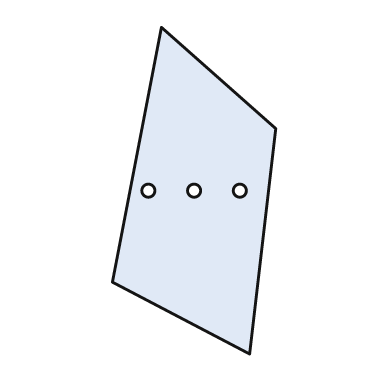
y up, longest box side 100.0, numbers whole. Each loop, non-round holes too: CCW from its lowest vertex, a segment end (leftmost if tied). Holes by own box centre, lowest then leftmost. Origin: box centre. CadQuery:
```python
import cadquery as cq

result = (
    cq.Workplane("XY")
    .moveTo(17.0, -50.0)
    .lineTo(25.0, 19.0)
    .lineTo(-10.0, 50.0)
    .lineTo(-25.0, -28.0)
    .close()
    .moveTo(-14.0, 0.0)
    .circle(2.0)
    .moveTo(0.0, 0.0)
    .circle(2.0)
    .moveTo(14.0, 0.0)
    .circle(2.0)
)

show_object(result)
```